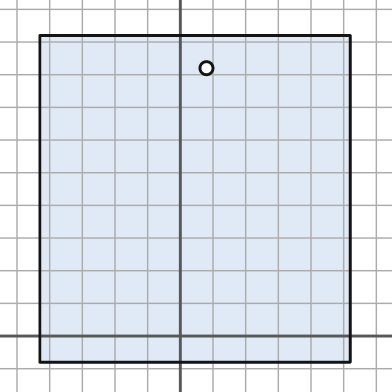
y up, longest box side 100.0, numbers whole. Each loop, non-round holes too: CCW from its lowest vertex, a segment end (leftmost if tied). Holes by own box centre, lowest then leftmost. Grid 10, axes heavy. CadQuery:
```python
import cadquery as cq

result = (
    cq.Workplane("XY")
    .moveTo(-43.0, -8.0)
    .lineTo(52.0, -8.0)
    .lineTo(52.0, 92.0)
    .lineTo(-43.0, 92.0)
    .close()
    .moveTo(8.0, 82.0)
    .circle(2.0)
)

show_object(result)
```